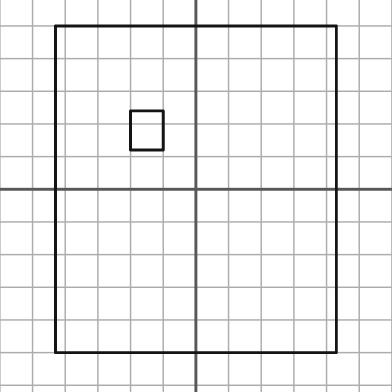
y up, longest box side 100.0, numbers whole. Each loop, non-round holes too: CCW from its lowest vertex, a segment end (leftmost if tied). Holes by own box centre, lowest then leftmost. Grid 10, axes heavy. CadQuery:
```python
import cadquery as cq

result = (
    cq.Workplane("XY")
    .moveTo(-43.0, -50.0)
    .lineTo(43.0, -50.0)
    .lineTo(43.0, 50.0)
    .lineTo(-43.0, 50.0)
    .close()
    .moveTo(-20.0, 12.0)
    .lineTo(-10.0, 12.0)
    .lineTo(-10.0, 24.0)
    .lineTo(-20.0, 24.0)
    .close()
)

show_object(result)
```